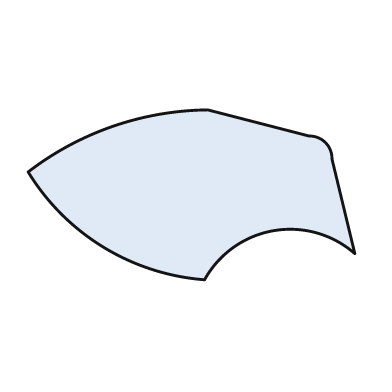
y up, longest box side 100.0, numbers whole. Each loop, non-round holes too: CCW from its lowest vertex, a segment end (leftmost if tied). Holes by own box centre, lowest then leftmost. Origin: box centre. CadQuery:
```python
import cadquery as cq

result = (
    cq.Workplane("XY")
    .moveTo(4.0, -26.0)
    .threePointArc((25.0, -11.0), (50.0, -18.0))
    .lineTo(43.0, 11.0)
    .threePointArc((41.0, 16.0), (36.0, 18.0))
    .lineTo(5.0, 26.0)
    .threePointArc((-24.0, 21.0), (-50.0, 7.0))
    .threePointArc((-27.0, -16.0), (4.0, -26.0))
    .close()
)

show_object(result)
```